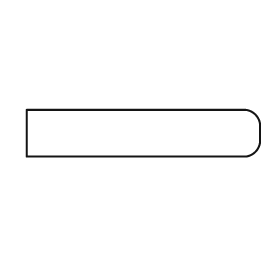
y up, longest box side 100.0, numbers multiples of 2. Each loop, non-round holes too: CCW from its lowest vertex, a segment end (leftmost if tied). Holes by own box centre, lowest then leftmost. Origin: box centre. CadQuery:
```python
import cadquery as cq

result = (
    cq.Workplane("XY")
    .moveTo(-50.0, -10.0)
    .lineTo(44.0, -10.0)
    .threePointArc((48.0, -8.0), (50.0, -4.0))
    .lineTo(50.0, 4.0)
    .threePointArc((48.0, 8.0), (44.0, 10.0))
    .lineTo(-50.0, 10.0)
    .close()
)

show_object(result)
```